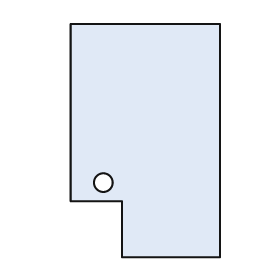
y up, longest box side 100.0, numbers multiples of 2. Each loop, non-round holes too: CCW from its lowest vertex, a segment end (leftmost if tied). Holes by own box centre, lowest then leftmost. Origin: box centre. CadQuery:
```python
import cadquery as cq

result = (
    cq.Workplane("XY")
    .moveTo(-10.0, -50.0)
    .lineTo(32.0, -50.0)
    .lineTo(32.0, 50.0)
    .lineTo(-32.0, 50.0)
    .lineTo(-32.0, -26.0)
    .lineTo(-10.0, -26.0)
    .close()
    .moveTo(-18.0, -18.0)
    .circle(4.0)
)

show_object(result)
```